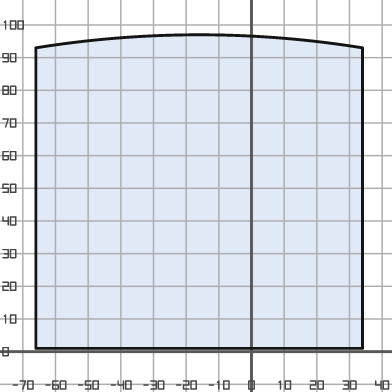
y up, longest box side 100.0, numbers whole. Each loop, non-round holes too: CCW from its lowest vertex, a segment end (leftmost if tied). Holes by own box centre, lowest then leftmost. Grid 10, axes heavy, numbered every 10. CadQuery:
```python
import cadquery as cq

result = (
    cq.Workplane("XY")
    .moveTo(-66.0, 1.0)
    .lineTo(34.0, 1.0)
    .lineTo(34.0, 93.0)
    .threePointArc((-16.0, 97.0), (-66.0, 93.0))
    .close()
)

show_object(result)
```